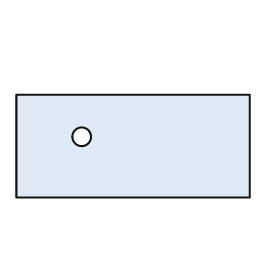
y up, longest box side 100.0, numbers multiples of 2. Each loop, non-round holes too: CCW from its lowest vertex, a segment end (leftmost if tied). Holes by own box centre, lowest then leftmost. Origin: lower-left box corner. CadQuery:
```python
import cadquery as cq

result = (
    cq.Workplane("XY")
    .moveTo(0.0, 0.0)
    .lineTo(100.0, 0.0)
    .lineTo(100.0, 44.0)
    .lineTo(0.0, 44.0)
    .close()
    .moveTo(28.0, 26.0)
    .circle(4.0)
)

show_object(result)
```